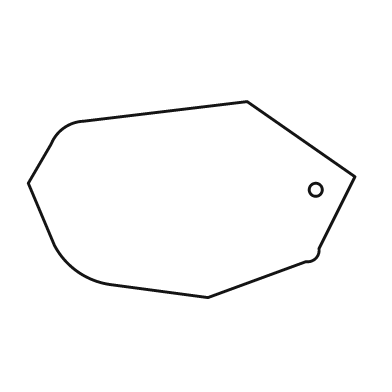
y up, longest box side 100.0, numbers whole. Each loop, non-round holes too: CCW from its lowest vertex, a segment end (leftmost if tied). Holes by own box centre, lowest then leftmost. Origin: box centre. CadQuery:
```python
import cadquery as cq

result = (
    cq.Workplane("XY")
    .moveTo(5.0, -30.0)
    .lineTo(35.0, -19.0)
    .threePointArc((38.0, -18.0), (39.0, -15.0))
    .lineTo(50.0, 7.0)
    .lineTo(17.0, 30.0)
    .lineTo(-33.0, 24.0)
    .threePointArc((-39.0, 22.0), (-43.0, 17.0))
    .lineTo(-50.0, 5.0)
    .lineTo(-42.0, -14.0)
    .threePointArc((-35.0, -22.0), (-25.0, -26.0))
    .close()
    .moveTo(38.0, 3.0)
    .circle(2.0)
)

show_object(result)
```